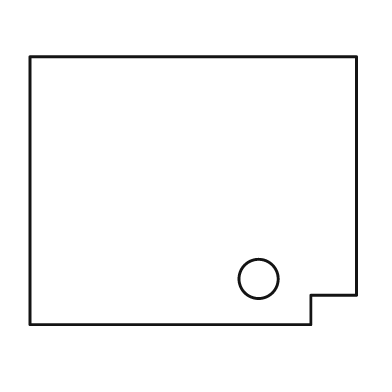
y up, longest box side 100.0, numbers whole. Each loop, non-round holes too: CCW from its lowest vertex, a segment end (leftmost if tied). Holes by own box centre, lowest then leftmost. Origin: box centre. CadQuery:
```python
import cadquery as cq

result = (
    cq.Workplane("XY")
    .moveTo(-50.0, -41.0)
    .lineTo(36.0, -41.0)
    .lineTo(36.0, -32.0)
    .lineTo(50.0, -32.0)
    .lineTo(50.0, 41.0)
    .lineTo(-50.0, 41.0)
    .close()
    .moveTo(20.0, -27.0)
    .circle(6.0)
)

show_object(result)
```